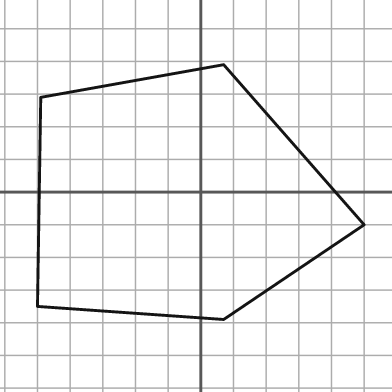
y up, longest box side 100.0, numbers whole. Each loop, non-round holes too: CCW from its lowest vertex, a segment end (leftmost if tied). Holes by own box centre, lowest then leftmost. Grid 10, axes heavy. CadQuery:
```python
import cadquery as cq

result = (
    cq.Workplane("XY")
    .moveTo(7.0, -39.0)
    .lineTo(50.0, -10.0)
    .lineTo(7.0, 39.0)
    .lineTo(-49.0, 29.0)
    .lineTo(-50.0, -35.0)
    .close()
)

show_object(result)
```